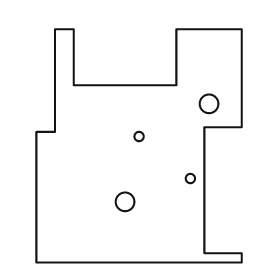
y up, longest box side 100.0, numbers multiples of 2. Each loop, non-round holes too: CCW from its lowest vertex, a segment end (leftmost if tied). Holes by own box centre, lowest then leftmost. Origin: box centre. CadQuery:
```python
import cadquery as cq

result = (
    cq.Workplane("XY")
    .moveTo(-44.0, -50.0)
    .lineTo(44.0, -50.0)
    .lineTo(44.0, -46.0)
    .lineTo(28.0, -46.0)
    .lineTo(28.0, 8.0)
    .lineTo(44.0, 8.0)
    .lineTo(44.0, 50.0)
    .lineTo(16.0, 50.0)
    .lineTo(16.0, 26.0)
    .lineTo(-28.0, 26.0)
    .lineTo(-28.0, 50.0)
    .lineTo(-36.0, 50.0)
    .lineTo(-36.0, 6.0)
    .lineTo(-44.0, 6.0)
    .close()
    .moveTo(-6.0, -24.0)
    .circle(4.0)
    .moveTo(22.0, -14.0)
    .circle(2.0)
    .moveTo(0.0, 4.0)
    .circle(2.0)
    .moveTo(30.0, 18.0)
    .circle(4.0)
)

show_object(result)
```